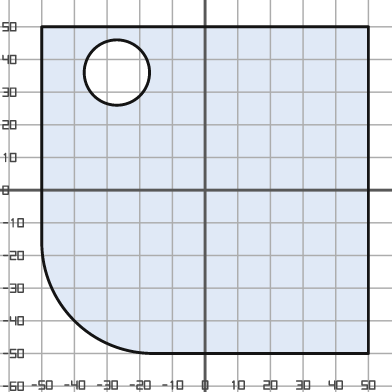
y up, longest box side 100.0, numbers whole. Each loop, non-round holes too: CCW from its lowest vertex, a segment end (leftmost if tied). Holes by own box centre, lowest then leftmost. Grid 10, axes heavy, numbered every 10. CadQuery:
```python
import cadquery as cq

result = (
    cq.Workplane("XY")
    .moveTo(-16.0, -50.0)
    .lineTo(50.0, -50.0)
    .lineTo(50.0, 50.0)
    .lineTo(-50.0, 50.0)
    .lineTo(-50.0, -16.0)
    .threePointArc((-40.0, -40.0), (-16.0, -50.0))
    .close()
    .moveTo(-27.0, 36.0)
    .circle(10.0)
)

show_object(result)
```